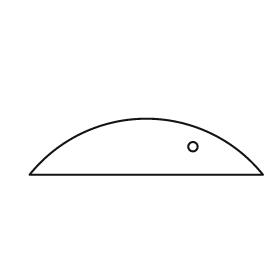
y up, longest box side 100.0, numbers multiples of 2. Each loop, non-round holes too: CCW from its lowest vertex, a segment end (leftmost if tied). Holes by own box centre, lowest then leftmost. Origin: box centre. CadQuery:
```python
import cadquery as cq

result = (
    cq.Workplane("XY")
    .moveTo(-50.0, -12.0)
    .lineTo(50.0, -12.0)
    .threePointArc((0.0, 12.0), (-50.0, -12.0))
    .close()
    .moveTo(20.0, 0.0)
    .circle(2.0)
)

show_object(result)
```